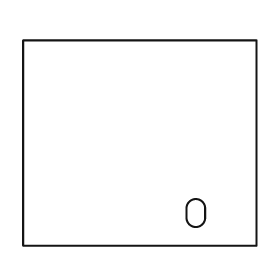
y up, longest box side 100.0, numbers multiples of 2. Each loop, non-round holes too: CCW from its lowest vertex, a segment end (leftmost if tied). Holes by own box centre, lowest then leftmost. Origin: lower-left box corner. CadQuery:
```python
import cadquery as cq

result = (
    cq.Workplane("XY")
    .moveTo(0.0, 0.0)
    .lineTo(100.0, 0.0)
    .lineTo(100.0, 88.0)
    .lineTo(0.0, 88.0)
    .close()
    .moveTo(70.0, 12.0)
    .threePointArc((74.0, 8.0), (78.0, 12.0))
    .lineTo(78.0, 16.0)
    .threePointArc((74.0, 20.0), (70.0, 16.0))
    .close()
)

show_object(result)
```